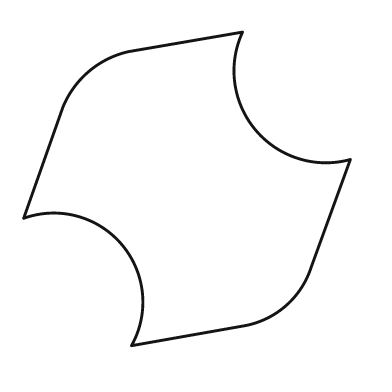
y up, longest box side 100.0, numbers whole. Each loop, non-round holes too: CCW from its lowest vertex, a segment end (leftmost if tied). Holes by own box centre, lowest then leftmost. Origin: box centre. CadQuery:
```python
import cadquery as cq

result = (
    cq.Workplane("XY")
    .moveTo(-17.0, -48.0)
    .lineTo(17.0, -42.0)
    .threePointArc((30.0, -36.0), (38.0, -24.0))
    .lineTo(50.0, 9.0)
    .threePointArc((21.0, 18.0), (17.0, 48.0))
    .lineTo(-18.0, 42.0)
    .threePointArc((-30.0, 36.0), (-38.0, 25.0))
    .lineTo(-50.0, -9.0)
    .threePointArc((-20.0, -17.0), (-17.0, -48.0))
    .close()
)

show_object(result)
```